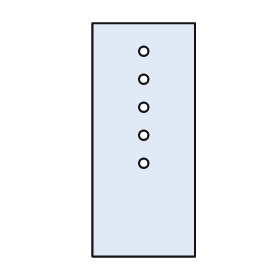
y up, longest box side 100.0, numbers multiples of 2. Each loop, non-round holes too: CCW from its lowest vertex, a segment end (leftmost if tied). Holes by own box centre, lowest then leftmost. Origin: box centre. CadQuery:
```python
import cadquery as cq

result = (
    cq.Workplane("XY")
    .moveTo(-22.0, -50.0)
    .lineTo(22.0, -50.0)
    .lineTo(22.0, 50.0)
    .lineTo(-22.0, 50.0)
    .close()
    .moveTo(0.0, -10.0)
    .circle(2.0)
    .moveTo(0.0, 2.0)
    .circle(2.0)
    .moveTo(0.0, 14.0)
    .circle(2.0)
    .moveTo(0.0, 26.0)
    .circle(2.0)
    .moveTo(0.0, 38.0)
    .circle(2.0)
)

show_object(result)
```